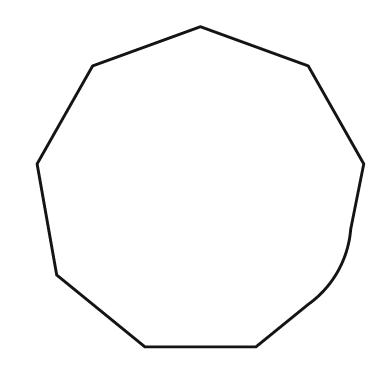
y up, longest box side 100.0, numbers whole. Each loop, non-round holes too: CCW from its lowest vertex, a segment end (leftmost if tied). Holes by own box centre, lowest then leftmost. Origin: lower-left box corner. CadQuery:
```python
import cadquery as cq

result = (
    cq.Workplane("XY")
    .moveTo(33.0, 0.0)
    .lineTo(67.0, 0.0)
    .lineTo(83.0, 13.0)
    .threePointArc((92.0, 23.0), (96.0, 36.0))
    .lineTo(100.0, 56.0)
    .lineTo(83.0, 86.0)
    .lineTo(50.0, 98.0)
    .lineTo(17.0, 86.0)
    .lineTo(0.0, 56.0)
    .lineTo(6.0, 22.0)
    .close()
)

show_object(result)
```